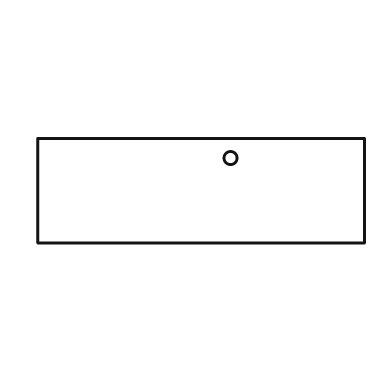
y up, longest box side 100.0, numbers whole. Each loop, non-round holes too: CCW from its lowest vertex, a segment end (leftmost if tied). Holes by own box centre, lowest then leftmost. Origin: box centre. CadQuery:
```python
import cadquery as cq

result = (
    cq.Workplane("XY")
    .moveTo(-50.0, -16.0)
    .lineTo(50.0, -16.0)
    .lineTo(50.0, 16.0)
    .lineTo(-50.0, 16.0)
    .close()
    .moveTo(9.0, 10.0)
    .circle(2.0)
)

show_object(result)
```